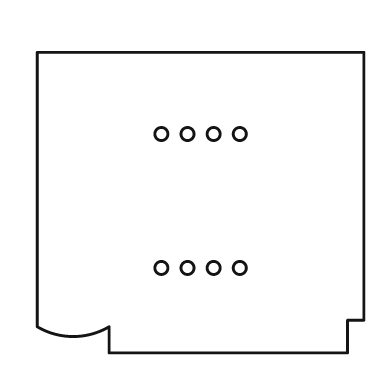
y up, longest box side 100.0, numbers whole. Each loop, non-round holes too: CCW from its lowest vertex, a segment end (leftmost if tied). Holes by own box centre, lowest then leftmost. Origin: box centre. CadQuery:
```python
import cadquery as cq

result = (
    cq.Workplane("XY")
    .moveTo(-28.0, -46.0)
    .lineTo(45.0, -46.0)
    .lineTo(45.0, -36.0)
    .lineTo(50.0, -36.0)
    .lineTo(50.0, 46.0)
    .lineTo(-50.0, 46.0)
    .lineTo(-50.0, -38.0)
    .threePointArc((-39.0, -41.0), (-28.0, -38.0))
    .close()
    .moveTo(-12.0, -20.0)
    .circle(2.0)
    .moveTo(-4.0, -20.0)
    .circle(2.0)
    .moveTo(4.0, -20.0)
    .circle(2.0)
    .moveTo(12.0, -20.0)
    .circle(2.0)
    .moveTo(-12.0, 21.0)
    .circle(2.0)
    .moveTo(-4.0, 21.0)
    .circle(2.0)
    .moveTo(4.0, 21.0)
    .circle(2.0)
    .moveTo(12.0, 21.0)
    .circle(2.0)
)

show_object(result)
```